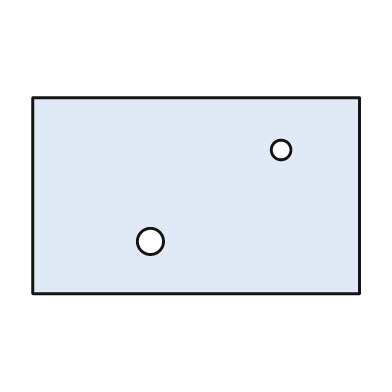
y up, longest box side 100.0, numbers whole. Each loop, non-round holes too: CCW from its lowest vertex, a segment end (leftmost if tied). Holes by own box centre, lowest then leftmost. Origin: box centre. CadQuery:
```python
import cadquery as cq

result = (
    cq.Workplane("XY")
    .moveTo(-50.0, -30.0)
    .lineTo(50.0, -30.0)
    .lineTo(50.0, 30.0)
    .lineTo(-50.0, 30.0)
    .close()
    .moveTo(-14.0, -14.0)
    .circle(4.0)
    .moveTo(26.0, 14.0)
    .circle(3.0)
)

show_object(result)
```